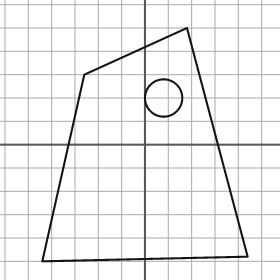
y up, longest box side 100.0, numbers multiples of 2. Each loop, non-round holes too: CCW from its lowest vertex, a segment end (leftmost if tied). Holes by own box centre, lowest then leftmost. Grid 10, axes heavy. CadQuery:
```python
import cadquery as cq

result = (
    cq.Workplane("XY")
    .moveTo(-44.0, -50.0)
    .lineTo(44.0, -48.0)
    .lineTo(18.0, 50.0)
    .lineTo(-26.0, 30.0)
    .close()
    .moveTo(8.0, 20.0)
    .circle(8.0)
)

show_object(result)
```